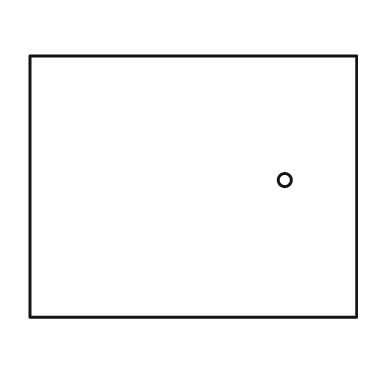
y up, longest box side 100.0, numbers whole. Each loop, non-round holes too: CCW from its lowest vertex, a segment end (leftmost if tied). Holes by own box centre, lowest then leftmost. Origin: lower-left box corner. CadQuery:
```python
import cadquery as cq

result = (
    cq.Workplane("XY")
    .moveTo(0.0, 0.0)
    .lineTo(100.0, 0.0)
    .lineTo(100.0, 80.0)
    .lineTo(0.0, 80.0)
    .close()
    .moveTo(78.0, 42.0)
    .circle(2.0)
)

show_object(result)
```